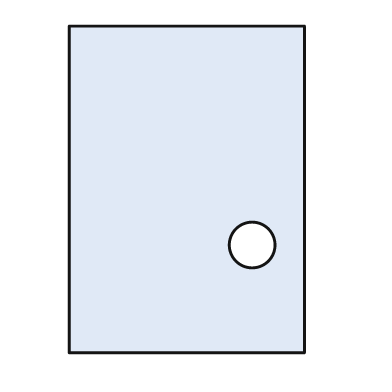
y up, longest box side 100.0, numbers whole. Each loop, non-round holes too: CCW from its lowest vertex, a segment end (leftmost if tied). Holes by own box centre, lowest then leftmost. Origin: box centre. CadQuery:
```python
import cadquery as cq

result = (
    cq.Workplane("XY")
    .moveTo(-36.0, -50.0)
    .lineTo(36.0, -50.0)
    .lineTo(36.0, 50.0)
    .lineTo(-36.0, 50.0)
    .close()
    .moveTo(20.0, -17.0)
    .circle(7.0)
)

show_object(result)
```